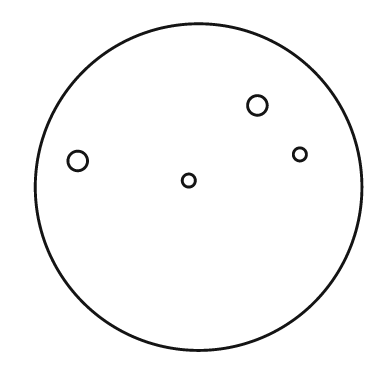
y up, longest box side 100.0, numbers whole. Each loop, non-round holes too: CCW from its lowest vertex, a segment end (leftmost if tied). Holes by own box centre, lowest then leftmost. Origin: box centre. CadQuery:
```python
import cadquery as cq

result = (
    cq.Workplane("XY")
    .moveTo(0.0, 0.0)
    .circle(50.0)
    .moveTo(-3.0, 2.0)
    .circle(2.0)
    .moveTo(-37.0, 8.0)
    .circle(3.0)
    .moveTo(31.0, 10.0)
    .circle(2.0)
    .moveTo(18.0, 25.0)
    .circle(3.0)
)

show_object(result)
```